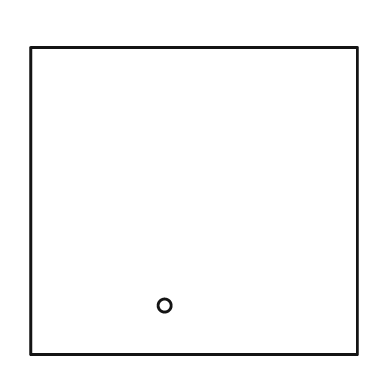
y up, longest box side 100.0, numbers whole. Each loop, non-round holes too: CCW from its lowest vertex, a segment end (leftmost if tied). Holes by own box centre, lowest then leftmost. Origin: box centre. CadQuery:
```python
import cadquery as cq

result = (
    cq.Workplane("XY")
    .moveTo(-50.0, -47.0)
    .lineTo(50.0, -47.0)
    .lineTo(50.0, 47.0)
    .lineTo(-50.0, 47.0)
    .close()
    .moveTo(-9.0, -32.0)
    .circle(2.0)
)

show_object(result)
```